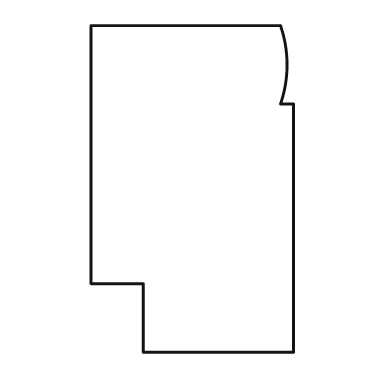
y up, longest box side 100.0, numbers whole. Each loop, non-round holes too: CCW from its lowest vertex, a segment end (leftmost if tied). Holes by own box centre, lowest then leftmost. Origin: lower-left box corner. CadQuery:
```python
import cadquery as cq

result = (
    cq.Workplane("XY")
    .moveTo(16.0, 0.0)
    .lineTo(62.0, 0.0)
    .lineTo(62.0, 76.0)
    .lineTo(58.0, 76.0)
    .threePointArc((60.0, 88.0), (58.0, 100.0))
    .lineTo(0.0, 100.0)
    .lineTo(0.0, 21.0)
    .lineTo(16.0, 21.0)
    .close()
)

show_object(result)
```